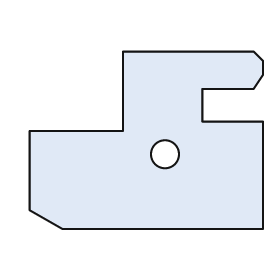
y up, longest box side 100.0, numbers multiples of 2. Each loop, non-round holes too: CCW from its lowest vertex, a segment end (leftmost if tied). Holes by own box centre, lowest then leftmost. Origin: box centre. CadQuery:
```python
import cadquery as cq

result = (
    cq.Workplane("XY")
    .moveTo(-36.0, -38.0)
    .lineTo(50.0, -38.0)
    .lineTo(50.0, 8.0)
    .lineTo(24.0, 8.0)
    .lineTo(24.0, 22.0)
    .lineTo(46.0, 22.0)
    .lineTo(50.0, 28.0)
    .lineTo(50.0, 34.0)
    .lineTo(46.0, 38.0)
    .lineTo(-10.0, 38.0)
    .lineTo(-10.0, 4.0)
    .lineTo(-50.0, 4.0)
    .lineTo(-50.0, -30.0)
    .close()
    .moveTo(8.0, -6.0)
    .circle(6.0)
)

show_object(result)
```